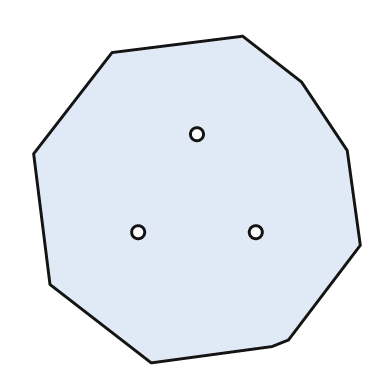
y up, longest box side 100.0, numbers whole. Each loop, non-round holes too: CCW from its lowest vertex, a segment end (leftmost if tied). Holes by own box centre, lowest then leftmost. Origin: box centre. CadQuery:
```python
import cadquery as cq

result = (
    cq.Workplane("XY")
    .moveTo(-14.0, -50.0)
    .lineTo(23.0, -45.0)
    .lineTo(28.0, -43.0)
    .lineTo(50.0, -14.0)
    .lineTo(46.0, 15.0)
    .lineTo(32.0, 36.0)
    .lineTo(14.0, 50.0)
    .lineTo(-26.0, 45.0)
    .lineTo(-50.0, 14.0)
    .lineTo(-45.0, -26.0)
    .close()
    .moveTo(-18.0, -10.0)
    .circle(2.0)
    .moveTo(18.0, -10.0)
    .circle(2.0)
    .moveTo(0.0, 20.0)
    .circle(2.0)
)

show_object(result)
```